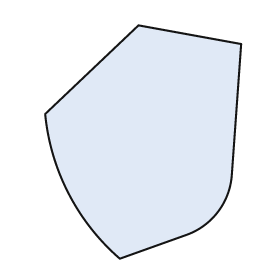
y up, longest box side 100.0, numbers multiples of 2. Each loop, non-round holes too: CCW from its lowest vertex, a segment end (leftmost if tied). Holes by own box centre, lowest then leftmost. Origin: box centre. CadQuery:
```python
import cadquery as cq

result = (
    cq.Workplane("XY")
    .moveTo(-10.0, -50.0)
    .lineTo(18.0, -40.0)
    .threePointArc((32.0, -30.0), (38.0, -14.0))
    .lineTo(42.0, 42.0)
    .lineTo(-2.0, 50.0)
    .lineTo(-42.0, 12.0)
    .threePointArc((-32.0, -22.0), (-10.0, -50.0))
    .close()
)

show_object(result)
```